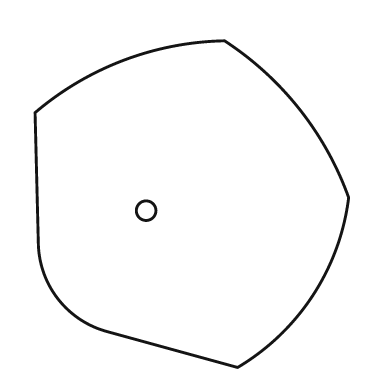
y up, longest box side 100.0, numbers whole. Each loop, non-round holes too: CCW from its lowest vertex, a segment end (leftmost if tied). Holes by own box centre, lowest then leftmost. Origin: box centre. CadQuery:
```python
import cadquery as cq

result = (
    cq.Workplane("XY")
    .moveTo(14.0, -50.0)
    .threePointArc((37.0, -28.0), (48.0, 2.0))
    .threePointArc((33.0, 29.0), (10.0, 50.0))
    .threePointArc((-21.0, 44.0), (-48.0, 28.0))
    .lineTo(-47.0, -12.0)
    .threePointArc((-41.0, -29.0), (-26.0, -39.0))
    .close()
    .moveTo(-14.0, -2.0)
    .circle(3.0)
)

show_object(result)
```